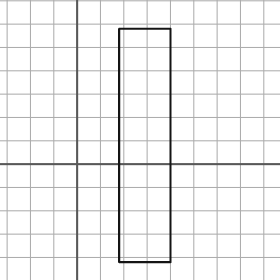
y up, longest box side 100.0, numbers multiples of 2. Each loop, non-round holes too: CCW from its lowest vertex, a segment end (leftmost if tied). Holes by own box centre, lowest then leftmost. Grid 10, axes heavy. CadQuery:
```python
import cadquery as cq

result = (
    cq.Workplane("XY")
    .moveTo(18.0, -42.0)
    .lineTo(40.0, -42.0)
    .lineTo(40.0, 58.0)
    .lineTo(18.0, 58.0)
    .close()
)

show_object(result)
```